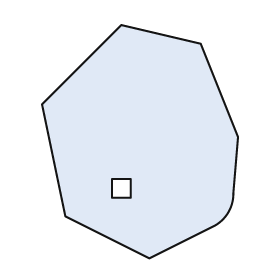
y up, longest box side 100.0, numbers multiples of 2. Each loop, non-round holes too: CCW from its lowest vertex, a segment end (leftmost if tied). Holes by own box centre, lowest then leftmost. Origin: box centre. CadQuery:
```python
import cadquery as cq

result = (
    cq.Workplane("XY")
    .moveTo(4.0, -50.0)
    .lineTo(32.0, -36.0)
    .threePointArc((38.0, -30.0), (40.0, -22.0))
    .lineTo(42.0, 2.0)
    .lineTo(26.0, 42.0)
    .lineTo(-8.0, 50.0)
    .lineTo(-42.0, 16.0)
    .lineTo(-32.0, -32.0)
    .close()
    .moveTo(-12.0, -24.0)
    .lineTo(-4.0, -24.0)
    .lineTo(-4.0, -16.0)
    .lineTo(-12.0, -16.0)
    .close()
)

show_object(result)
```